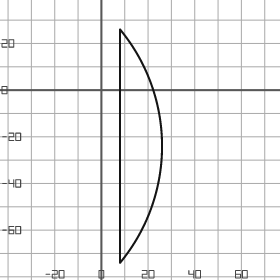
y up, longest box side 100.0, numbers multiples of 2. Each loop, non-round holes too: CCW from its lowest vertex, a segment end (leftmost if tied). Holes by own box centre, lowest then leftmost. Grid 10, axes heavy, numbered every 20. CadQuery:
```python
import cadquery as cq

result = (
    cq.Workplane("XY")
    .moveTo(8.0, -74.0)
    .threePointArc((26.0, -24.0), (8.0, 26.0))
    .close()
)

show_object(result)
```